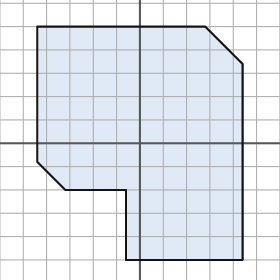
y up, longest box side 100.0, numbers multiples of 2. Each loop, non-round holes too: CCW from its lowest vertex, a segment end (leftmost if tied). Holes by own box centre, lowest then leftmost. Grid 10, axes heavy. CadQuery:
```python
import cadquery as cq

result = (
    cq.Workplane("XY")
    .moveTo(-6.0, -50.0)
    .lineTo(44.0, -50.0)
    .lineTo(44.0, 34.0)
    .lineTo(28.0, 50.0)
    .lineTo(-44.0, 50.0)
    .lineTo(-44.0, -8.0)
    .lineTo(-32.0, -20.0)
    .lineTo(-6.0, -20.0)
    .close()
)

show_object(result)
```